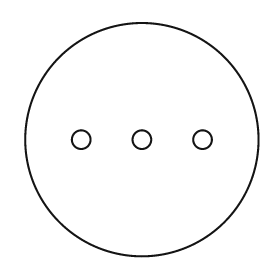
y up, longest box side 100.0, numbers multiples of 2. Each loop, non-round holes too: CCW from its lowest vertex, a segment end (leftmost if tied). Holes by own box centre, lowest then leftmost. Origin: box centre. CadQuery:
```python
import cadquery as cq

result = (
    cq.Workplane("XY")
    .moveTo(0.0, 0.0)
    .circle(50.0)
    .moveTo(-26.0, 0.0)
    .circle(4.0)
    .moveTo(0.0, 0.0)
    .circle(4.0)
    .moveTo(26.0, 0.0)
    .circle(4.0)
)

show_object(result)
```